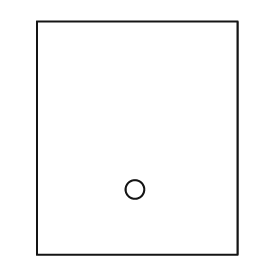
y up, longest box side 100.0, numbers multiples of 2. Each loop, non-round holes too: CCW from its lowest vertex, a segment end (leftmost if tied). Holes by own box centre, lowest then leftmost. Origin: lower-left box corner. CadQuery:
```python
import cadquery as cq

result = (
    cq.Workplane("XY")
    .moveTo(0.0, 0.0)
    .lineTo(86.0, 0.0)
    .lineTo(86.0, 100.0)
    .lineTo(0.0, 100.0)
    .close()
    .moveTo(42.0, 28.0)
    .circle(4.0)
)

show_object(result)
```